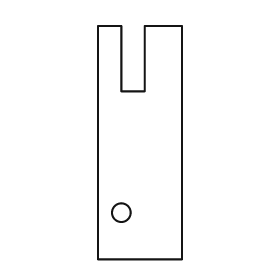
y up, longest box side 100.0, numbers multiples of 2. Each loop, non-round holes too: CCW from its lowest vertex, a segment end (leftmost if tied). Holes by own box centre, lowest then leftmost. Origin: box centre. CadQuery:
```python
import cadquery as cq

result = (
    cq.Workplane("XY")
    .moveTo(-18.0, -50.0)
    .lineTo(18.0, -50.0)
    .lineTo(18.0, 50.0)
    .lineTo(2.0, 50.0)
    .lineTo(2.0, 22.0)
    .lineTo(-8.0, 22.0)
    .lineTo(-8.0, 50.0)
    .lineTo(-18.0, 50.0)
    .close()
    .moveTo(-8.0, -30.0)
    .circle(4.0)
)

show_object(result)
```